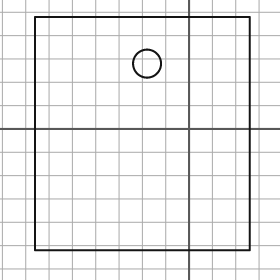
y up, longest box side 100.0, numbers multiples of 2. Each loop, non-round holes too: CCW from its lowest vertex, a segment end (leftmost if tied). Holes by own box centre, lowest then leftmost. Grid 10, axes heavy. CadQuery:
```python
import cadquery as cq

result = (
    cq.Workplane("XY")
    .moveTo(-66.0, -52.0)
    .lineTo(26.0, -52.0)
    .lineTo(26.0, 48.0)
    .lineTo(-66.0, 48.0)
    .close()
    .moveTo(-18.0, 28.0)
    .circle(6.0)
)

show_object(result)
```